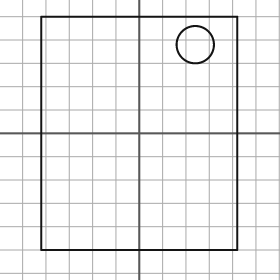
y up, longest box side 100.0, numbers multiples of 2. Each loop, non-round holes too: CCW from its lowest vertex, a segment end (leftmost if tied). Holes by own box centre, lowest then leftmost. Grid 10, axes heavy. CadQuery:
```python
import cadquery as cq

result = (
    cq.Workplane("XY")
    .moveTo(-42.0, -50.0)
    .lineTo(42.0, -50.0)
    .lineTo(42.0, 50.0)
    .lineTo(-42.0, 50.0)
    .close()
    .moveTo(24.0, 38.0)
    .circle(8.0)
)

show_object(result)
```